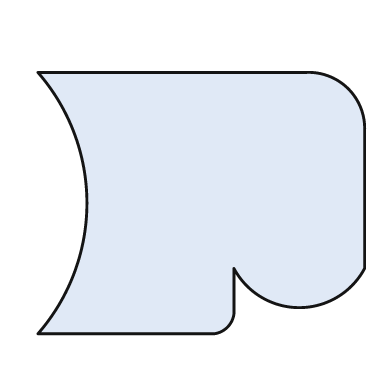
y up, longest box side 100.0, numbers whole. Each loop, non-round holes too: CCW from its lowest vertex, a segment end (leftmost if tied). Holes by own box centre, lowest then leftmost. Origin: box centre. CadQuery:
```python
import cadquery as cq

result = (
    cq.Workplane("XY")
    .moveTo(-50.0, -40.0)
    .lineTo(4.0, -40.0)
    .threePointArc((8.0, -38.0), (10.0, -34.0))
    .lineTo(10.0, -20.0)
    .threePointArc((30.0, -32.0), (50.0, -20.0))
    .lineTo(50.0, 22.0)
    .threePointArc((45.0, 35.0), (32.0, 40.0))
    .lineTo(-50.0, 40.0)
    .threePointArc((-35.0, 0.0), (-50.0, -40.0))
    .close()
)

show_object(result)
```